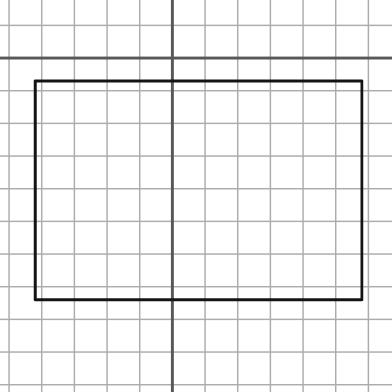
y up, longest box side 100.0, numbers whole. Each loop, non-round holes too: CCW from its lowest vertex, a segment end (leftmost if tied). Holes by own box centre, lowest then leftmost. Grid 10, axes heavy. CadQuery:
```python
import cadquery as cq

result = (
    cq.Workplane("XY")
    .moveTo(-42.0, -74.0)
    .lineTo(58.0, -74.0)
    .lineTo(58.0, -7.0)
    .lineTo(-42.0, -7.0)
    .close()
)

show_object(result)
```